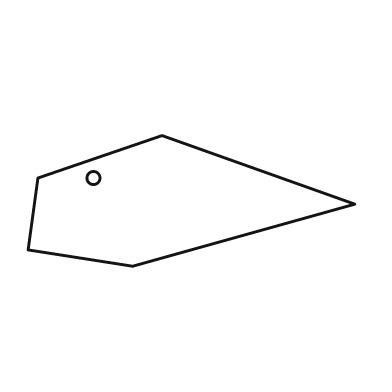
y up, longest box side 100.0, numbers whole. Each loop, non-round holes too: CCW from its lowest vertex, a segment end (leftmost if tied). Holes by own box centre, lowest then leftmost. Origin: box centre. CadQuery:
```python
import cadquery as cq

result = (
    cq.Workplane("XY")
    .moveTo(-18.0, -20.0)
    .lineTo(50.0, -1.0)
    .lineTo(-9.0, 20.0)
    .lineTo(-47.0, 7.0)
    .lineTo(-50.0, -15.0)
    .close()
    .moveTo(-30.0, 7.0)
    .circle(2.0)
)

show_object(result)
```